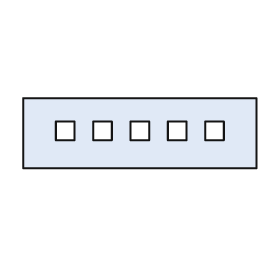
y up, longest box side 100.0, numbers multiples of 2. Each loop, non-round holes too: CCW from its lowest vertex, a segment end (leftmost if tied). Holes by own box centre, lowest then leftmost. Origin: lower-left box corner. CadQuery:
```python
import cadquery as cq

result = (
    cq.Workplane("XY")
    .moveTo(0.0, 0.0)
    .lineTo(100.0, 0.0)
    .lineTo(100.0, 30.0)
    .lineTo(0.0, 30.0)
    .close()
    .moveTo(14.0, 12.0)
    .lineTo(22.0, 12.0)
    .lineTo(22.0, 20.0)
    .lineTo(14.0, 20.0)
    .close()
    .moveTo(30.0, 12.0)
    .lineTo(38.0, 12.0)
    .lineTo(38.0, 20.0)
    .lineTo(30.0, 20.0)
    .close()
    .moveTo(46.0, 12.0)
    .lineTo(54.0, 12.0)
    .lineTo(54.0, 20.0)
    .lineTo(46.0, 20.0)
    .close()
    .moveTo(62.0, 12.0)
    .lineTo(70.0, 12.0)
    .lineTo(70.0, 20.0)
    .lineTo(62.0, 20.0)
    .close()
    .moveTo(78.0, 12.0)
    .lineTo(86.0, 12.0)
    .lineTo(86.0, 20.0)
    .lineTo(78.0, 20.0)
    .close()
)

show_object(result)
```